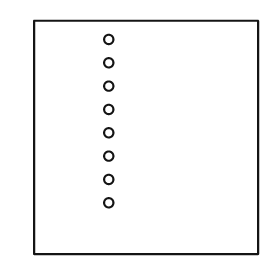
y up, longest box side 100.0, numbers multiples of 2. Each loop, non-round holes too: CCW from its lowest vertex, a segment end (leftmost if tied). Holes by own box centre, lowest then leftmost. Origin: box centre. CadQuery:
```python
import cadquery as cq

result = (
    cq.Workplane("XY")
    .moveTo(-48.0, -50.0)
    .lineTo(48.0, -50.0)
    .lineTo(48.0, 50.0)
    .lineTo(-48.0, 50.0)
    .close()
    .moveTo(-16.0, -28.0)
    .circle(2.0)
    .moveTo(-16.0, -18.0)
    .circle(2.0)
    .moveTo(-16.0, -8.0)
    .circle(2.0)
    .moveTo(-16.0, 2.0)
    .circle(2.0)
    .moveTo(-16.0, 12.0)
    .circle(2.0)
    .moveTo(-16.0, 22.0)
    .circle(2.0)
    .moveTo(-16.0, 32.0)
    .circle(2.0)
    .moveTo(-16.0, 42.0)
    .circle(2.0)
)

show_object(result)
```